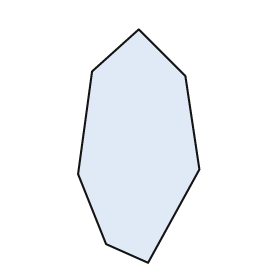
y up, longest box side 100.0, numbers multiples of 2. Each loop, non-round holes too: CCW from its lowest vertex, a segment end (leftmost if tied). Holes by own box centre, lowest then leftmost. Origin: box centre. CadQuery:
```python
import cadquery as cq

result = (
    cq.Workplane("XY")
    .moveTo(4.0, -50.0)
    .lineTo(26.0, -10.0)
    .lineTo(20.0, 30.0)
    .lineTo(0.0, 50.0)
    .lineTo(-20.0, 32.0)
    .lineTo(-26.0, -12.0)
    .lineTo(-14.0, -42.0)
    .close()
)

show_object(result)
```